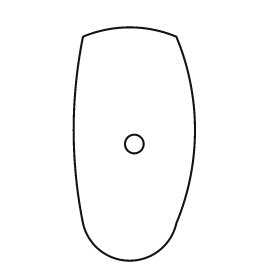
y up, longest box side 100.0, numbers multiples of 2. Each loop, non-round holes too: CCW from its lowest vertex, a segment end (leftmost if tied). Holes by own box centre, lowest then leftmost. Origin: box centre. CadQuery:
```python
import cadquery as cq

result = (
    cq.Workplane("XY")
    .moveTo(-22.0, -34.0)
    .threePointArc((-2.0, -50.0), (18.0, -34.0))
    .threePointArc((26.0, 6.0), (18.0, 46.0))
    .threePointArc((-2.0, 50.0), (-22.0, 46.0))
    .threePointArc((-26.0, 6.0), (-22.0, -34.0))
    .close()
    .moveTo(0.0, 0.0)
    .circle(4.0)
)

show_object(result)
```